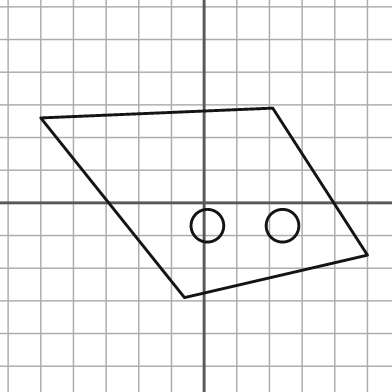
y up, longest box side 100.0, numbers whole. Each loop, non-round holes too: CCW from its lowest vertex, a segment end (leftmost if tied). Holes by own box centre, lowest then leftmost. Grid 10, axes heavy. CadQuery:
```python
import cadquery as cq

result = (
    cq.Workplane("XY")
    .moveTo(-6.0, -29.0)
    .lineTo(50.0, -16.0)
    .lineTo(21.0, 29.0)
    .lineTo(-50.0, 26.0)
    .close()
    .moveTo(1.0, -7.0)
    .circle(5.0)
    .moveTo(24.0, -7.0)
    .circle(5.0)
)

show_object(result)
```